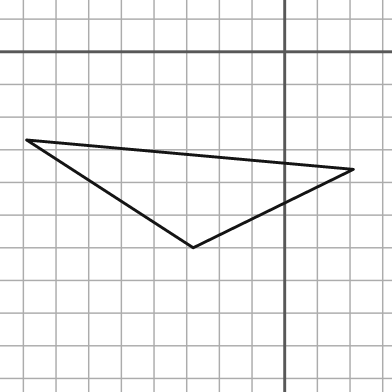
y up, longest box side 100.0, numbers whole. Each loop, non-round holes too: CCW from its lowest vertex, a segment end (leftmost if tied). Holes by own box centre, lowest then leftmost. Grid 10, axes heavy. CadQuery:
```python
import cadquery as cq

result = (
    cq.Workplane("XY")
    .moveTo(-28.0, -60.0)
    .lineTo(21.0, -36.0)
    .lineTo(-79.0, -27.0)
    .close()
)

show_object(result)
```